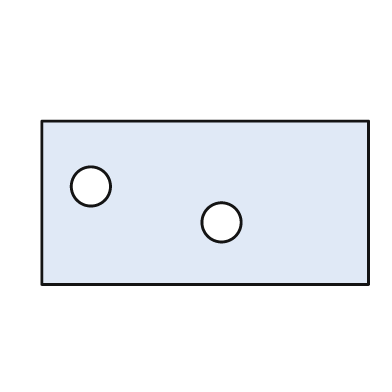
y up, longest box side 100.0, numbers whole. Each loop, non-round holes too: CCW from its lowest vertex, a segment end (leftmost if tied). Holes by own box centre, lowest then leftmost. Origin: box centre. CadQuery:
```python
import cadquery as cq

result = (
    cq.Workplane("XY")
    .moveTo(-50.0, -25.0)
    .lineTo(50.0, -25.0)
    .lineTo(50.0, 25.0)
    .lineTo(-50.0, 25.0)
    .close()
    .moveTo(5.0, -6.0)
    .circle(6.0)
    .moveTo(-35.0, 5.0)
    .circle(6.0)
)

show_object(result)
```